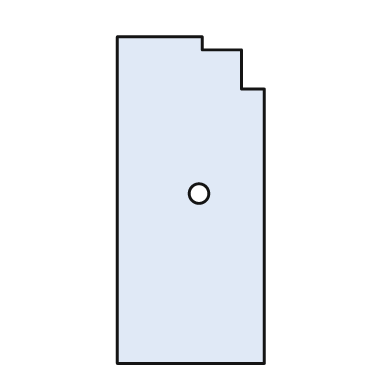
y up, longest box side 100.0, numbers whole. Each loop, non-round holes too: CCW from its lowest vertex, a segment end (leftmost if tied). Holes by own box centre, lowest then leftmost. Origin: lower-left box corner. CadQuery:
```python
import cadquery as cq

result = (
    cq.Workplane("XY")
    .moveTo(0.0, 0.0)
    .lineTo(45.0, 0.0)
    .lineTo(45.0, 84.0)
    .lineTo(38.0, 84.0)
    .lineTo(38.0, 96.0)
    .lineTo(26.0, 96.0)
    .lineTo(26.0, 100.0)
    .lineTo(0.0, 100.0)
    .close()
    .moveTo(25.0, 52.0)
    .circle(3.0)
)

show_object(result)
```